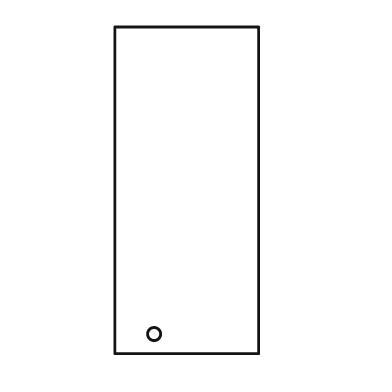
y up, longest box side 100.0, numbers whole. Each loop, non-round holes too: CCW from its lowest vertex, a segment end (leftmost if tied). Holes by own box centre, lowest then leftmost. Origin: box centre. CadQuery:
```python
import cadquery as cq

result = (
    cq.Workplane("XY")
    .moveTo(-22.0, -50.0)
    .lineTo(22.0, -50.0)
    .lineTo(22.0, 50.0)
    .lineTo(-22.0, 50.0)
    .close()
    .moveTo(-10.0, -44.0)
    .circle(2.0)
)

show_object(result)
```